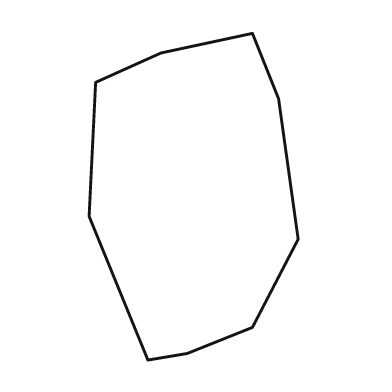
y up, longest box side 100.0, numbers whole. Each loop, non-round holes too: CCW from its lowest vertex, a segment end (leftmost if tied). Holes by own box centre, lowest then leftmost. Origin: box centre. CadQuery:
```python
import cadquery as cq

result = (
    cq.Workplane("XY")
    .moveTo(-14.0, -50.0)
    .lineTo(-2.0, -48.0)
    .lineTo(18.0, -40.0)
    .lineTo(32.0, -13.0)
    .lineTo(26.0, 30.0)
    .lineTo(18.0, 50.0)
    .lineTo(-10.0, 44.0)
    .lineTo(-30.0, 35.0)
    .lineTo(-32.0, -6.0)
    .close()
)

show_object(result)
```